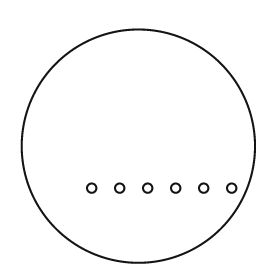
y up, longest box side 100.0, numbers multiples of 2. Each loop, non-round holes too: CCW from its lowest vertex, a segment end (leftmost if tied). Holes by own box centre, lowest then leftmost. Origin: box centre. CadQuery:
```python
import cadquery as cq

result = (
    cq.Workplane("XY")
    .moveTo(0.0, 0.0)
    .circle(50.0)
    .moveTo(-20.0, -18.0)
    .circle(2.0)
    .moveTo(-8.0, -18.0)
    .circle(2.0)
    .moveTo(4.0, -18.0)
    .circle(2.0)
    .moveTo(16.0, -18.0)
    .circle(2.0)
    .moveTo(28.0, -18.0)
    .circle(2.0)
    .moveTo(40.0, -18.0)
    .circle(2.0)
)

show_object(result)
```